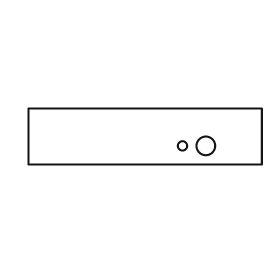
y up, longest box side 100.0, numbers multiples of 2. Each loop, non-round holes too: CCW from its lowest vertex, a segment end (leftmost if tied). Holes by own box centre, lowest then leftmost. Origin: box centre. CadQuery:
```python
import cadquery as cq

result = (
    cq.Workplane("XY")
    .moveTo(-50.0, -12.0)
    .lineTo(50.0, -12.0)
    .lineTo(50.0, 12.0)
    .lineTo(-50.0, 12.0)
    .close()
    .moveTo(16.0, -4.0)
    .circle(2.0)
    .moveTo(26.0, -4.0)
    .circle(4.0)
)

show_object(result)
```